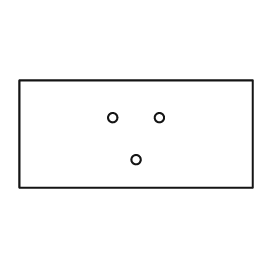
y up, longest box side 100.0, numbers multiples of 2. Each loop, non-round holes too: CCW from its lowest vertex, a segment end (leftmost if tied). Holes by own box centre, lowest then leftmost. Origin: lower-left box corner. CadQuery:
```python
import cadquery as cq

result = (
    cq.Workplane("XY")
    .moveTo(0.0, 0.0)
    .lineTo(100.0, 0.0)
    .lineTo(100.0, 46.0)
    .lineTo(0.0, 46.0)
    .close()
    .moveTo(50.0, 12.0)
    .circle(2.0)
    .moveTo(40.0, 30.0)
    .circle(2.0)
    .moveTo(60.0, 30.0)
    .circle(2.0)
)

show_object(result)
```